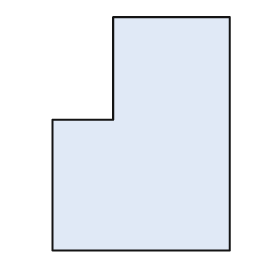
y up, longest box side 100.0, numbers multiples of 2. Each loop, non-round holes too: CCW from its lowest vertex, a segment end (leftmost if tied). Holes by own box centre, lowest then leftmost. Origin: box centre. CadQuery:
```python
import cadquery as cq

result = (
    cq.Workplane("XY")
    .moveTo(-38.0, -50.0)
    .lineTo(38.0, -50.0)
    .lineTo(38.0, 50.0)
    .lineTo(-12.0, 50.0)
    .lineTo(-12.0, 6.0)
    .lineTo(-38.0, 6.0)
    .close()
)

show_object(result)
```